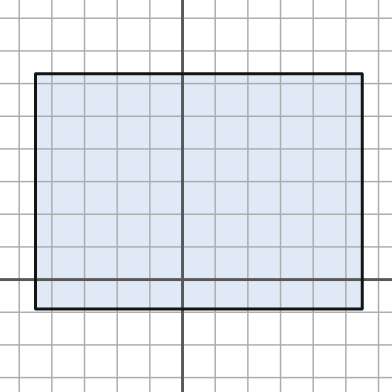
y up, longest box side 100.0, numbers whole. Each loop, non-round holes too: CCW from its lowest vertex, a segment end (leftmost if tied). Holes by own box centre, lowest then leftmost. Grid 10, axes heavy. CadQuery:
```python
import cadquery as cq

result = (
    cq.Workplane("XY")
    .moveTo(-45.0, -9.0)
    .lineTo(55.0, -9.0)
    .lineTo(55.0, 63.0)
    .lineTo(-45.0, 63.0)
    .close()
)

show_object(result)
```